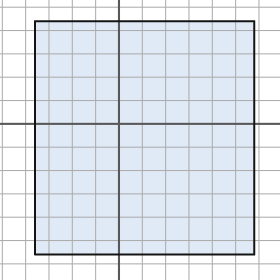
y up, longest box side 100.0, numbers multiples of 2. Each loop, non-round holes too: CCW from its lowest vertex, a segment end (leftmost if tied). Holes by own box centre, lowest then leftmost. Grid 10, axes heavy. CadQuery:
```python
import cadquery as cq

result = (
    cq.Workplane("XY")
    .moveTo(-36.0, -56.0)
    .lineTo(58.0, -56.0)
    .lineTo(58.0, 44.0)
    .lineTo(-36.0, 44.0)
    .close()
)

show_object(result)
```